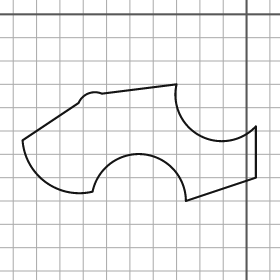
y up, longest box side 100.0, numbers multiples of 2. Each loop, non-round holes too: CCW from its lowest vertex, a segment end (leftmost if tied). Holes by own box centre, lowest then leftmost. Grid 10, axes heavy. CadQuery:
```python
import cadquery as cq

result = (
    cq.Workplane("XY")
    .moveTo(-26.0, -80.0)
    .lineTo(4.0, -70.0)
    .lineTo(4.0, -48.0)
    .threePointArc((-20.0, -52.0), (-30.0, -30.0))
    .lineTo(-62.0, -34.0)
    .threePointArc((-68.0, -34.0), (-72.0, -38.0))
    .lineTo(-96.0, -54.0)
    .threePointArc((-86.0, -72.0), (-66.0, -76.0))
    .threePointArc((-44.0, -60.0), (-26.0, -80.0))
    .close()
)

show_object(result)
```